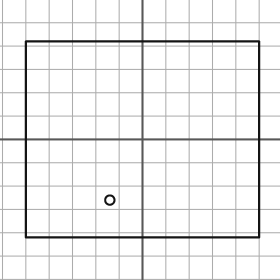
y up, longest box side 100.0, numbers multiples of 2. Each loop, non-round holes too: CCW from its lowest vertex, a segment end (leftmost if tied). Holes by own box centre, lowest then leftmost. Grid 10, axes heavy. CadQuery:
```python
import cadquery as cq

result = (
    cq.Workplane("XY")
    .moveTo(-50.0, -42.0)
    .lineTo(50.0, -42.0)
    .lineTo(50.0, 42.0)
    .lineTo(-50.0, 42.0)
    .close()
    .moveTo(-14.0, -26.0)
    .circle(2.0)
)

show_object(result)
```